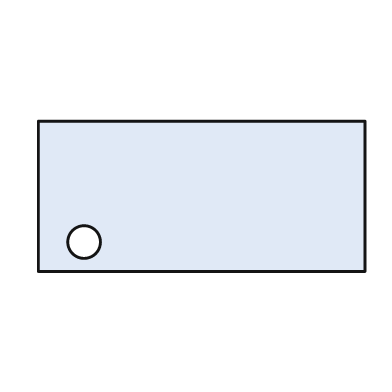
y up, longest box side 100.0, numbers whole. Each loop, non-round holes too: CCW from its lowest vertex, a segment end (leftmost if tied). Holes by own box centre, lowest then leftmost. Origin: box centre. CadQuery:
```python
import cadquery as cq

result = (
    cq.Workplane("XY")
    .moveTo(-50.0, -23.0)
    .lineTo(50.0, -23.0)
    .lineTo(50.0, 23.0)
    .lineTo(-50.0, 23.0)
    .close()
    .moveTo(-36.0, -14.0)
    .circle(5.0)
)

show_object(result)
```